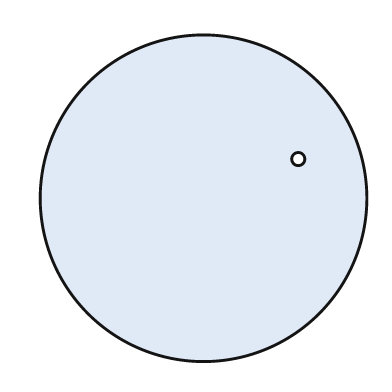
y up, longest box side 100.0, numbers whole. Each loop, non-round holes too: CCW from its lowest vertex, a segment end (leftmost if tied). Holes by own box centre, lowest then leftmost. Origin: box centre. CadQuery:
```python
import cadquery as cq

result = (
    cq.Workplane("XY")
    .moveTo(0.0, 0.0)
    .circle(50.0)
    .moveTo(29.0, 12.0)
    .circle(2.0)
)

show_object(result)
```